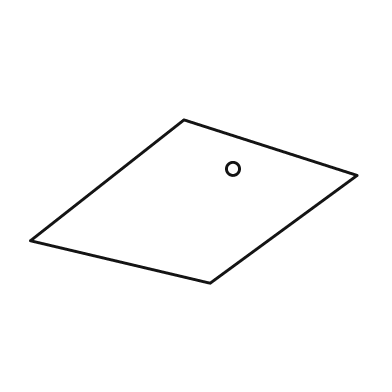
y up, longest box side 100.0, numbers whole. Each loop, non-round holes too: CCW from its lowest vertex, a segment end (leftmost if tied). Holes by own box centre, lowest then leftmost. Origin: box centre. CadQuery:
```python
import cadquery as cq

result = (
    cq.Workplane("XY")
    .moveTo(5.0, -25.0)
    .lineTo(50.0, 8.0)
    .lineTo(-3.0, 25.0)
    .lineTo(-50.0, -12.0)
    .close()
    .moveTo(12.0, 10.0)
    .circle(2.0)
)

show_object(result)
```